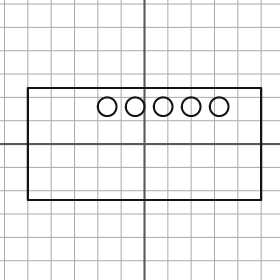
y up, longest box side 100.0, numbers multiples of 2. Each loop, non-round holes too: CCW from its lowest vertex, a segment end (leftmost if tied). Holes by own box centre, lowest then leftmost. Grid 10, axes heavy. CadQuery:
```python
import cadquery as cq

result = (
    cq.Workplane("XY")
    .moveTo(-50.0, -24.0)
    .lineTo(50.0, -24.0)
    .lineTo(50.0, 24.0)
    .lineTo(-50.0, 24.0)
    .close()
    .moveTo(-16.0, 16.0)
    .circle(4.0)
    .moveTo(-4.0, 16.0)
    .circle(4.0)
    .moveTo(8.0, 16.0)
    .circle(4.0)
    .moveTo(20.0, 16.0)
    .circle(4.0)
    .moveTo(32.0, 16.0)
    .circle(4.0)
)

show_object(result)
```